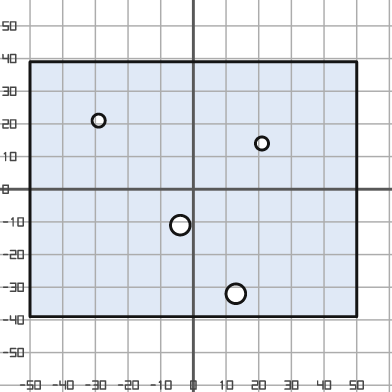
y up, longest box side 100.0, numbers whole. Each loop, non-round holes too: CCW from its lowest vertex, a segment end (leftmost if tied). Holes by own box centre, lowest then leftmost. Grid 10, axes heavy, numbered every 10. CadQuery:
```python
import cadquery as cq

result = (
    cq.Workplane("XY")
    .moveTo(-50.0, -39.0)
    .lineTo(50.0, -39.0)
    .lineTo(50.0, 39.0)
    .lineTo(-50.0, 39.0)
    .close()
    .moveTo(13.0, -32.0)
    .circle(3.0)
    .moveTo(-4.0, -11.0)
    .circle(3.0)
    .moveTo(21.0, 14.0)
    .circle(2.0)
    .moveTo(-29.0, 21.0)
    .circle(2.0)
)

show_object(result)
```